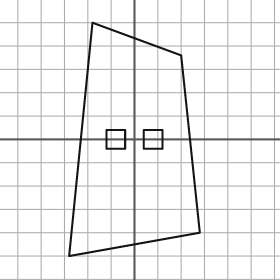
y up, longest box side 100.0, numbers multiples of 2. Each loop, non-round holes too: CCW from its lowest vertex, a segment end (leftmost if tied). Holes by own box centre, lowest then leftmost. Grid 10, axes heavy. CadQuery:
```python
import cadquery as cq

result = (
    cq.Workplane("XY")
    .moveTo(-28.0, -50.0)
    .lineTo(28.0, -40.0)
    .lineTo(20.0, 36.0)
    .lineTo(-18.0, 50.0)
    .close()
    .moveTo(-12.0, -4.0)
    .lineTo(-4.0, -4.0)
    .lineTo(-4.0, 4.0)
    .lineTo(-12.0, 4.0)
    .close()
    .moveTo(4.0, -4.0)
    .lineTo(12.0, -4.0)
    .lineTo(12.0, 4.0)
    .lineTo(4.0, 4.0)
    .close()
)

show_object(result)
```